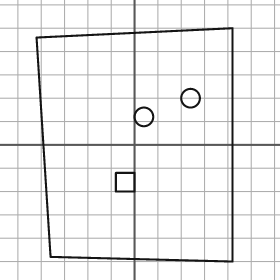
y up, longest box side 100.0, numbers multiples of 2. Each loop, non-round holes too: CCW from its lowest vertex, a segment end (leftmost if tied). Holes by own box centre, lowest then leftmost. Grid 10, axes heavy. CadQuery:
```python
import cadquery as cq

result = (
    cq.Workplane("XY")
    .moveTo(42.0, -50.0)
    .lineTo(42.0, 50.0)
    .lineTo(-42.0, 46.0)
    .lineTo(-36.0, -48.0)
    .close()
    .moveTo(-8.0, -20.0)
    .lineTo(0.0, -20.0)
    .lineTo(0.0, -12.0)
    .lineTo(-8.0, -12.0)
    .close()
    .moveTo(4.0, 12.0)
    .circle(4.0)
    .moveTo(24.0, 20.0)
    .circle(4.0)
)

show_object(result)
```